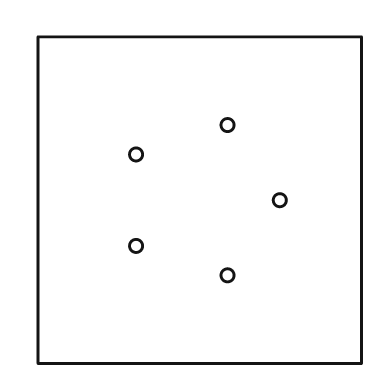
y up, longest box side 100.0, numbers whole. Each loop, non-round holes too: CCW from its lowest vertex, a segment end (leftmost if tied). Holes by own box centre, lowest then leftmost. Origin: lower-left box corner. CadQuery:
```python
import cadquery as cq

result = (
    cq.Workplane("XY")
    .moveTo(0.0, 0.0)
    .lineTo(99.0, 0.0)
    .lineTo(99.0, 100.0)
    .lineTo(0.0, 100.0)
    .close()
    .moveTo(58.0, 27.0)
    .circle(2.0)
    .moveTo(30.0, 36.0)
    .circle(2.0)
    .moveTo(74.0, 50.0)
    .circle(2.0)
    .moveTo(30.0, 64.0)
    .circle(2.0)
    .moveTo(58.0, 73.0)
    .circle(2.0)
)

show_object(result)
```